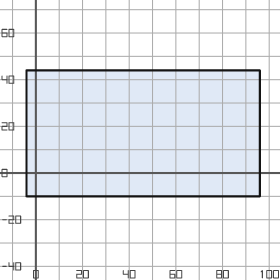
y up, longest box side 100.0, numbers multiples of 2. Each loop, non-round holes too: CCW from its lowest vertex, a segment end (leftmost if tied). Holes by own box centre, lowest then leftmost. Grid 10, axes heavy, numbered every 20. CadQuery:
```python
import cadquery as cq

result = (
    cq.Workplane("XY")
    .moveTo(-4.0, -10.0)
    .lineTo(96.0, -10.0)
    .lineTo(96.0, 44.0)
    .lineTo(-4.0, 44.0)
    .close()
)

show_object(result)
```